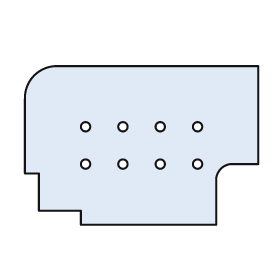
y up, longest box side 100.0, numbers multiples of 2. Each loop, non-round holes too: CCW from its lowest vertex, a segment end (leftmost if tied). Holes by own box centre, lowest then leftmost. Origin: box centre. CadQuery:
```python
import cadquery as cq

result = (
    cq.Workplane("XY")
    .moveTo(-26.0, -34.0)
    .lineTo(32.0, -34.0)
    .lineTo(32.0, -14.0)
    .threePointArc((34.0, -10.0), (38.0, -8.0))
    .lineTo(50.0, -8.0)
    .lineTo(50.0, 34.0)
    .lineTo(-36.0, 34.0)
    .threePointArc((-46.0, 30.0), (-50.0, 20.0))
    .lineTo(-50.0, -12.0)
    .lineTo(-44.0, -12.0)
    .lineTo(-44.0, -28.0)
    .lineTo(-26.0, -28.0)
    .close()
    .moveTo(-24.0, -8.0)
    .circle(2.0)
    .moveTo(-8.0, -8.0)
    .circle(2.0)
    .moveTo(8.0, -8.0)
    .circle(2.0)
    .moveTo(24.0, -8.0)
    .circle(2.0)
    .moveTo(-24.0, 8.0)
    .circle(2.0)
    .moveTo(-8.0, 8.0)
    .circle(2.0)
    .moveTo(8.0, 8.0)
    .circle(2.0)
    .moveTo(24.0, 8.0)
    .circle(2.0)
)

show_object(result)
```